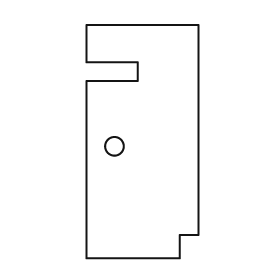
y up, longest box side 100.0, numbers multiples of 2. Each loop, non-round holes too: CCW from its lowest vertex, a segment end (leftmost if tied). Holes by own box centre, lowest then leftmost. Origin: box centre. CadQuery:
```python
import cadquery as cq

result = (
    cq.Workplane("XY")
    .moveTo(-24.0, -50.0)
    .lineTo(16.0, -50.0)
    .lineTo(16.0, -40.0)
    .lineTo(24.0, -40.0)
    .lineTo(24.0, 50.0)
    .lineTo(-24.0, 50.0)
    .lineTo(-24.0, 34.0)
    .lineTo(-2.0, 34.0)
    .lineTo(-2.0, 26.0)
    .lineTo(-24.0, 26.0)
    .close()
    .moveTo(-12.0, -2.0)
    .circle(4.0)
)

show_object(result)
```